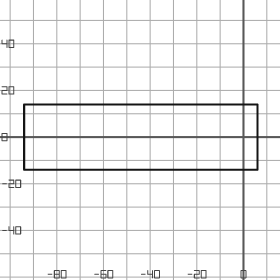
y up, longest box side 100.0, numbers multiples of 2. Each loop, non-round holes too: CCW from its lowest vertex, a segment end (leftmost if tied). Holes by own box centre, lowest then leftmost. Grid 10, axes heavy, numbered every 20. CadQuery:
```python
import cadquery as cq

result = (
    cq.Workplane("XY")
    .moveTo(-94.0, -14.0)
    .lineTo(6.0, -14.0)
    .lineTo(6.0, 14.0)
    .lineTo(-94.0, 14.0)
    .close()
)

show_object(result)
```